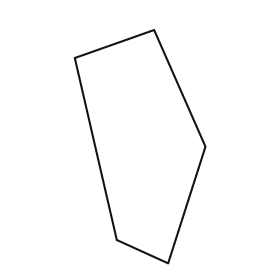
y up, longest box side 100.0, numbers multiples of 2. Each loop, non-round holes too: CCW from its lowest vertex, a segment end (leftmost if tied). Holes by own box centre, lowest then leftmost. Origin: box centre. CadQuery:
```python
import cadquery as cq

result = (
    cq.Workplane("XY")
    .moveTo(12.0, -50.0)
    .lineTo(28.0, 0.0)
    .lineTo(6.0, 50.0)
    .lineTo(-28.0, 38.0)
    .lineTo(-10.0, -40.0)
    .close()
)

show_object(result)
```